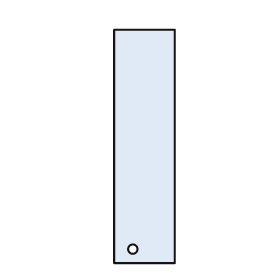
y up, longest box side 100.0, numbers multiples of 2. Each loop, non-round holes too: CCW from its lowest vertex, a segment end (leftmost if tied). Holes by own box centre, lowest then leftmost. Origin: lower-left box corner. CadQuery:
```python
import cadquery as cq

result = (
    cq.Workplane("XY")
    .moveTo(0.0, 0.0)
    .lineTo(26.0, 0.0)
    .lineTo(26.0, 100.0)
    .lineTo(0.0, 100.0)
    .close()
    .moveTo(8.0, 6.0)
    .circle(2.0)
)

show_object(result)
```